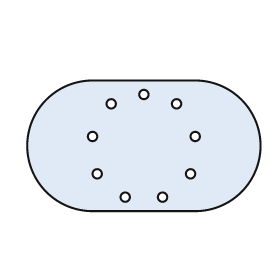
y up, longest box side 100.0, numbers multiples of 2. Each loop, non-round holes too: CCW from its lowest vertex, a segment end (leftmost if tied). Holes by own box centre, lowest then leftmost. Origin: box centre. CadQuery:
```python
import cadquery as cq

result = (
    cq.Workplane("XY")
    .moveTo(-22.0, -28.0)
    .lineTo(22.0, -28.0)
    .threePointArc((50.0, 0.0), (22.0, 28.0))
    .lineTo(-22.0, 28.0)
    .threePointArc((-50.0, 0.0), (-22.0, -28.0))
    .close()
    .moveTo(-8.0, -22.0)
    .circle(2.0)
    .moveTo(8.0, -22.0)
    .circle(2.0)
    .moveTo(-20.0, -12.0)
    .circle(2.0)
    .moveTo(20.0, -12.0)
    .circle(2.0)
    .moveTo(-22.0, 4.0)
    .circle(2.0)
    .moveTo(22.0, 4.0)
    .circle(2.0)
    .moveTo(-14.0, 18.0)
    .circle(2.0)
    .moveTo(14.0, 18.0)
    .circle(2.0)
    .moveTo(0.0, 22.0)
    .circle(2.0)
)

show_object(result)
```